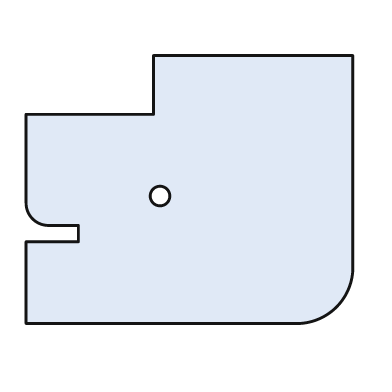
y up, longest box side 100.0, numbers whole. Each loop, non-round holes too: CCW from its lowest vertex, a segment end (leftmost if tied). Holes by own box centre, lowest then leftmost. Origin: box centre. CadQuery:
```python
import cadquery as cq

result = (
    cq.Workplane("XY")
    .moveTo(-50.0, -41.0)
    .lineTo(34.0, -41.0)
    .threePointArc((45.0, -36.0), (50.0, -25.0))
    .lineTo(50.0, 41.0)
    .lineTo(-11.0, 41.0)
    .lineTo(-11.0, 23.0)
    .lineTo(-50.0, 23.0)
    .lineTo(-50.0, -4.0)
    .threePointArc((-48.0, -9.0), (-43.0, -11.0))
    .lineTo(-34.0, -11.0)
    .lineTo(-34.0, -16.0)
    .lineTo(-50.0, -16.0)
    .close()
    .moveTo(-9.0, -2.0)
    .circle(3.0)
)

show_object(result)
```